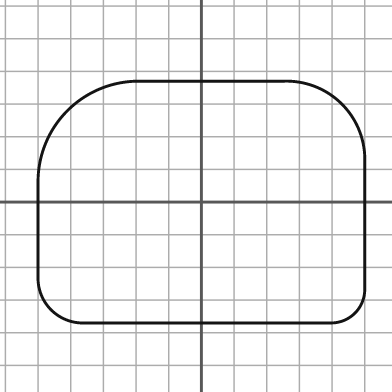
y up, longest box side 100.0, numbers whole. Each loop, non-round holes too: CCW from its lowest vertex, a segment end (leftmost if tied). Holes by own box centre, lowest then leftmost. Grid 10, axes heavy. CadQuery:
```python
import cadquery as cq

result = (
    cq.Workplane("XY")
    .moveTo(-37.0, -37.0)
    .lineTo(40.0, -37.0)
    .threePointArc((47.0, -34.0), (50.0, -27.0))
    .lineTo(50.0, 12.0)
    .threePointArc((43.0, 30.0), (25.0, 37.0))
    .lineTo(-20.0, 37.0)
    .threePointArc((-41.0, 28.0), (-50.0, 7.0))
    .lineTo(-50.0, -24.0)
    .threePointArc((-46.0, -33.0), (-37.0, -37.0))
    .close()
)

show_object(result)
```